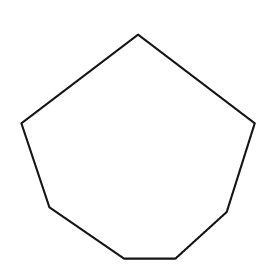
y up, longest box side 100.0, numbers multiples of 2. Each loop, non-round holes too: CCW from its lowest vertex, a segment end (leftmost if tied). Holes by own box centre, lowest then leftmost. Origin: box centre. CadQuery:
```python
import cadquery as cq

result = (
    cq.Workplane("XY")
    .moveTo(-6.0, -48.0)
    .lineTo(16.0, -48.0)
    .lineTo(38.0, -28.0)
    .lineTo(50.0, 10.0)
    .lineTo(0.0, 48.0)
    .lineTo(-50.0, 10.0)
    .lineTo(-38.0, -26.0)
    .close()
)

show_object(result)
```